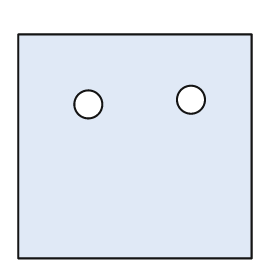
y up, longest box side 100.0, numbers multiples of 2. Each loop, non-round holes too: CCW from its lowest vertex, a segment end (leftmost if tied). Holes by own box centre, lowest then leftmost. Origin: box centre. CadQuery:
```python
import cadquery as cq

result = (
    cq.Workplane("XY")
    .moveTo(-50.0, -48.0)
    .lineTo(50.0, -48.0)
    .lineTo(50.0, 48.0)
    .lineTo(-50.0, 48.0)
    .close()
    .moveTo(-20.0, 18.0)
    .circle(6.0)
    .moveTo(24.0, 20.0)
    .circle(6.0)
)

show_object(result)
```